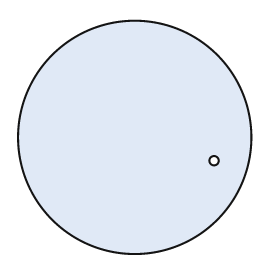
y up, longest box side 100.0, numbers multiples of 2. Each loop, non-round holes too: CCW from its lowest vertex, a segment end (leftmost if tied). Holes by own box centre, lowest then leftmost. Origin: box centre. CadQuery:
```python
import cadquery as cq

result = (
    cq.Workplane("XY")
    .moveTo(0.0, 0.0)
    .circle(50.0)
    .moveTo(34.0, -10.0)
    .circle(2.0)
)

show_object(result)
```